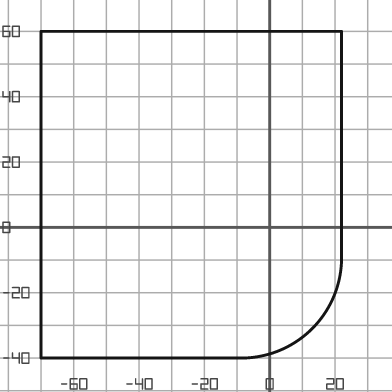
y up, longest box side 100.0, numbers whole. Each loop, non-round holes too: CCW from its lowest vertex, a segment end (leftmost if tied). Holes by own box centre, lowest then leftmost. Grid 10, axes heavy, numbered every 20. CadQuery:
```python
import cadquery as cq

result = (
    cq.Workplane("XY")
    .moveTo(-70.0, -40.0)
    .lineTo(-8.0, -40.0)
    .threePointArc((13.0, -31.0), (22.0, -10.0))
    .lineTo(22.0, 60.0)
    .lineTo(-70.0, 60.0)
    .close()
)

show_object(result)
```